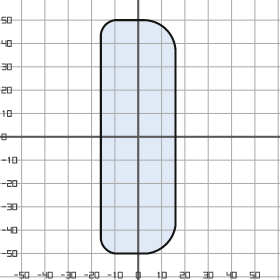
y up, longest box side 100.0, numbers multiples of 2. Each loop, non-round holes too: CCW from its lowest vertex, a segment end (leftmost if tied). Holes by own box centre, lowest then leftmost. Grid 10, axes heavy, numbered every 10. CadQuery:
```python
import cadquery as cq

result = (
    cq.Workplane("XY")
    .moveTo(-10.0, -50.0)
    .lineTo(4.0, -50.0)
    .threePointArc((12.0, -46.0), (16.0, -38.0))
    .lineTo(16.0, 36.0)
    .threePointArc((12.0, 46.0), (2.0, 50.0))
    .lineTo(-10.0, 50.0)
    .threePointArc((-14.0, 48.0), (-16.0, 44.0))
    .lineTo(-16.0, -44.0)
    .threePointArc((-14.0, -48.0), (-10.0, -50.0))
    .close()
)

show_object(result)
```